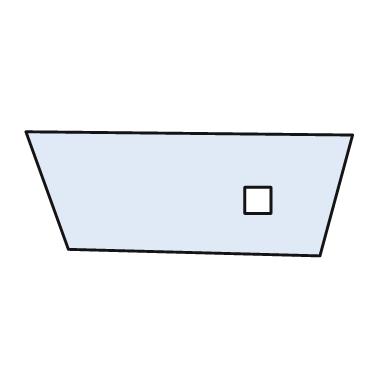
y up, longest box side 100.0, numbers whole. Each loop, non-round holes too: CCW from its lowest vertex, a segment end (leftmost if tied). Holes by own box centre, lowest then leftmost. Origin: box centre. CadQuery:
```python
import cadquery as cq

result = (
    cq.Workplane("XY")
    .moveTo(40.0, -19.0)
    .lineTo(50.0, 18.0)
    .lineTo(-50.0, 19.0)
    .lineTo(-37.0, -17.0)
    .close()
    .moveTo(17.0, -6.0)
    .lineTo(25.0, -6.0)
    .lineTo(25.0, 2.0)
    .lineTo(17.0, 2.0)
    .close()
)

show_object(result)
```